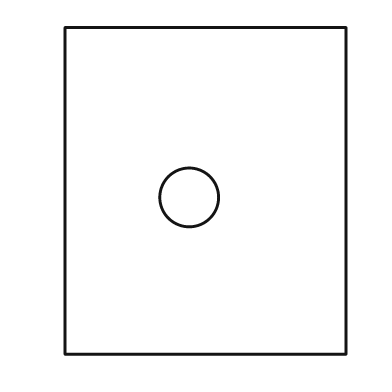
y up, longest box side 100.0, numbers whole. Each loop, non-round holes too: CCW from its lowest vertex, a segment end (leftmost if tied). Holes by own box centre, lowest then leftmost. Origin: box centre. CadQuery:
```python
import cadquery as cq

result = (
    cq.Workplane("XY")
    .moveTo(-43.0, -50.0)
    .lineTo(43.0, -50.0)
    .lineTo(43.0, 50.0)
    .lineTo(-43.0, 50.0)
    .close()
    .moveTo(-5.0, -2.0)
    .circle(9.0)
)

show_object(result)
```